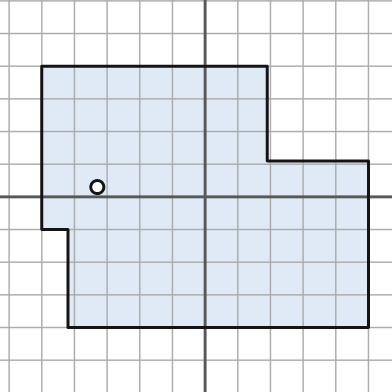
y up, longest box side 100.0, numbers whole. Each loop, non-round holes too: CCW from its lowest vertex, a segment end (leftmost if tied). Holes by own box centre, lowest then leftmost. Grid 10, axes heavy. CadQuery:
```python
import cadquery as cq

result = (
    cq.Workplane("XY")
    .moveTo(-42.0, -40.0)
    .lineTo(50.0, -40.0)
    .lineTo(50.0, 11.0)
    .lineTo(19.0, 11.0)
    .lineTo(19.0, 40.0)
    .lineTo(-50.0, 40.0)
    .lineTo(-50.0, -10.0)
    .lineTo(-42.0, -10.0)
    .close()
    .moveTo(-33.0, 3.0)
    .circle(2.0)
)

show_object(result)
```